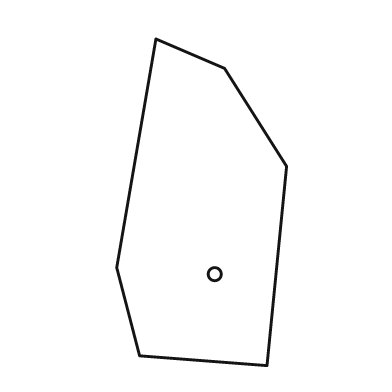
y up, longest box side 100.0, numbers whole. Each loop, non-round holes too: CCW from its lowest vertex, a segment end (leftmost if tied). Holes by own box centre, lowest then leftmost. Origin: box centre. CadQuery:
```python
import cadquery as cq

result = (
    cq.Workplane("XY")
    .moveTo(20.0, -50.0)
    .lineTo(26.0, 11.0)
    .lineTo(7.0, 41.0)
    .lineTo(-14.0, 50.0)
    .lineTo(-26.0, -20.0)
    .lineTo(-19.0, -47.0)
    .close()
    .moveTo(4.0, -22.0)
    .circle(2.0)
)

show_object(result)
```